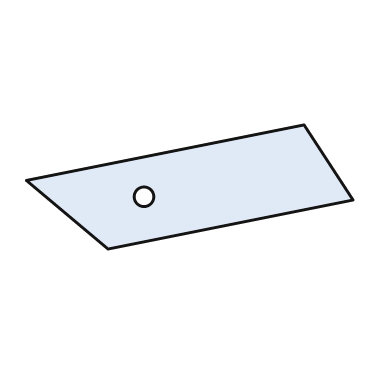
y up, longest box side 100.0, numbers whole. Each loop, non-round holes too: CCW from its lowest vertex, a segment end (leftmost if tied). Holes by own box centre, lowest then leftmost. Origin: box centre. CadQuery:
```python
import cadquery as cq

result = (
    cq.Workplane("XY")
    .moveTo(-25.0, -19.0)
    .lineTo(50.0, -4.0)
    .lineTo(35.0, 19.0)
    .lineTo(-50.0, 2.0)
    .close()
    .moveTo(-14.0, -3.0)
    .circle(3.0)
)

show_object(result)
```